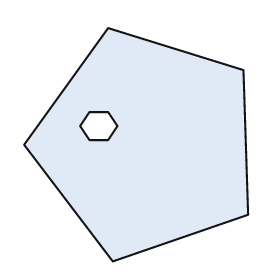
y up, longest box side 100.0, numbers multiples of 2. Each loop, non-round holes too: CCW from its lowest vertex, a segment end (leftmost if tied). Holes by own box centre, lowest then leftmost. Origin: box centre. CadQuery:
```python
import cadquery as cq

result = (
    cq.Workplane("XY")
    .moveTo(-10.0, -50.0)
    .lineTo(48.0, -30.0)
    .lineTo(46.0, 32.0)
    .lineTo(-12.0, 50.0)
    .lineTo(-48.0, 0.0)
    .close()
    .moveTo(-20.0, 2.0)
    .lineTo(-12.0, 2.0)
    .lineTo(-8.0, 8.0)
    .lineTo(-12.0, 14.0)
    .lineTo(-20.0, 14.0)
    .lineTo(-24.0, 8.0)
    .close()
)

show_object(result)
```